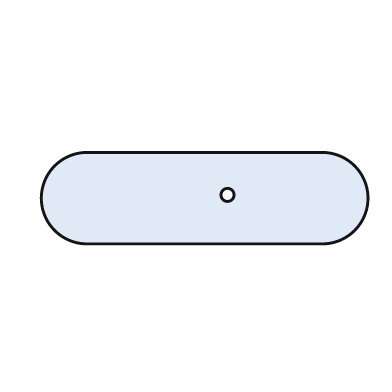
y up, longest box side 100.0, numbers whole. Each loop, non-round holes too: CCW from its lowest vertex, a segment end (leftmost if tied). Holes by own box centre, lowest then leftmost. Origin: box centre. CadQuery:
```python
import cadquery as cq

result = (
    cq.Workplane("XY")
    .moveTo(-36.0, -14.0)
    .lineTo(36.0, -14.0)
    .threePointArc((50.0, 0.0), (36.0, 14.0))
    .lineTo(-36.0, 14.0)
    .threePointArc((-50.0, 0.0), (-36.0, -14.0))
    .close()
    .moveTo(7.0, 1.0)
    .circle(2.0)
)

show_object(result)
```